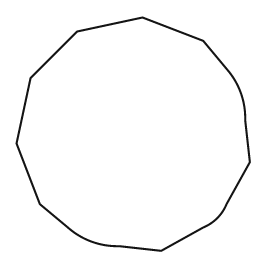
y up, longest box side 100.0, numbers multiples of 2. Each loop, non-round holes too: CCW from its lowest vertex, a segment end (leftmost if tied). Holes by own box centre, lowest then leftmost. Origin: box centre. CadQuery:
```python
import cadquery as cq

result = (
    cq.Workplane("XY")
    .moveTo(12.0, -50.0)
    .lineTo(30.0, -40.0)
    .threePointArc((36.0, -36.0), (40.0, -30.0))
    .lineTo(50.0, -12.0)
    .lineTo(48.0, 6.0)
    .threePointArc((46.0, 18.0), (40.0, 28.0))
    .lineTo(30.0, 40.0)
    .lineTo(4.0, 50.0)
    .lineTo(-24.0, 44.0)
    .lineTo(-44.0, 24.0)
    .lineTo(-50.0, -4.0)
    .lineTo(-40.0, -30.0)
    .lineTo(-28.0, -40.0)
    .threePointArc((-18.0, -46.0), (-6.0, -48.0))
    .close()
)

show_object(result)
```